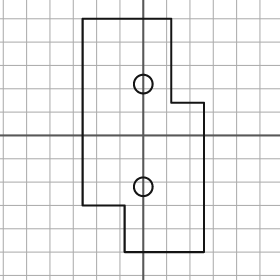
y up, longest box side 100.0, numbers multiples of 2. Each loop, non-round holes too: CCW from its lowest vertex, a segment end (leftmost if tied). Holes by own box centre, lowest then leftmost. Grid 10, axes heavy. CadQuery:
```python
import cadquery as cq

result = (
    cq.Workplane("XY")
    .moveTo(-8.0, -50.0)
    .lineTo(26.0, -50.0)
    .lineTo(26.0, 14.0)
    .lineTo(12.0, 14.0)
    .lineTo(12.0, 50.0)
    .lineTo(-26.0, 50.0)
    .lineTo(-26.0, -30.0)
    .lineTo(-8.0, -30.0)
    .close()
    .moveTo(0.0, -22.0)
    .circle(4.0)
    .moveTo(0.0, 22.0)
    .circle(4.0)
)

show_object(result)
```